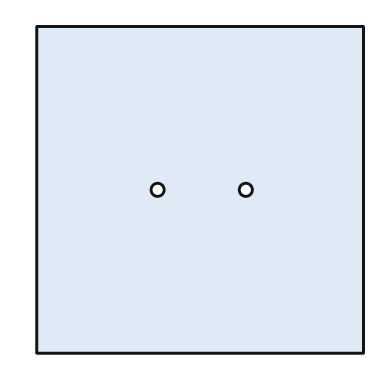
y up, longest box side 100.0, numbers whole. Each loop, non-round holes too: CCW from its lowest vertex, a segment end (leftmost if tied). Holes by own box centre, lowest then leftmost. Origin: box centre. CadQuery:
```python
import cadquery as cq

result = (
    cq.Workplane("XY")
    .moveTo(-50.0, -50.0)
    .lineTo(50.0, -50.0)
    .lineTo(50.0, 50.0)
    .lineTo(-50.0, 50.0)
    .close()
    .moveTo(-13.0, 0.0)
    .circle(2.0)
    .moveTo(14.0, 0.0)
    .circle(2.0)
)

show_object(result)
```